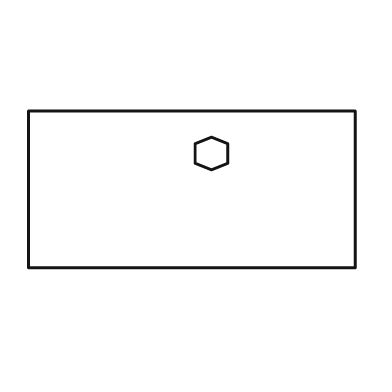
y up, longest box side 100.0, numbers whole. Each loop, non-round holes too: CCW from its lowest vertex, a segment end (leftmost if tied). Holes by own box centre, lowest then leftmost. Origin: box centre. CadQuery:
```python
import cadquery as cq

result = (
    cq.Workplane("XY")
    .moveTo(-50.0, -24.0)
    .lineTo(50.0, -24.0)
    .lineTo(50.0, 24.0)
    .lineTo(-50.0, 24.0)
    .close()
    .moveTo(6.0, 6.0)
    .lineTo(11.0, 8.0)
    .lineTo(11.0, 14.0)
    .lineTo(6.0, 16.0)
    .lineTo(1.0, 14.0)
    .lineTo(1.0, 8.0)
    .close()
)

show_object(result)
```